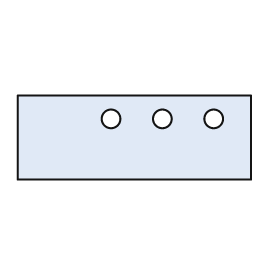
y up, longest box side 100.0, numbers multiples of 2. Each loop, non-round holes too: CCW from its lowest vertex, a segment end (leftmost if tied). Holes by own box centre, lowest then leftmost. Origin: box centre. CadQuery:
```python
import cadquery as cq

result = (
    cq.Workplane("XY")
    .moveTo(-50.0, -18.0)
    .lineTo(50.0, -18.0)
    .lineTo(50.0, 18.0)
    .lineTo(-50.0, 18.0)
    .close()
    .moveTo(-10.0, 8.0)
    .circle(4.0)
    .moveTo(12.0, 8.0)
    .circle(4.0)
    .moveTo(34.0, 8.0)
    .circle(4.0)
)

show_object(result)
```